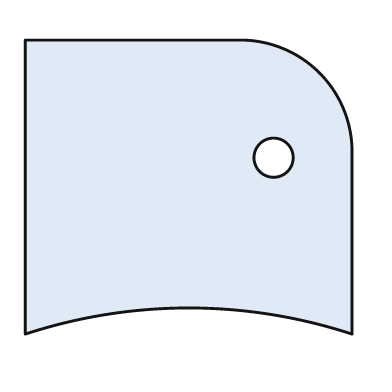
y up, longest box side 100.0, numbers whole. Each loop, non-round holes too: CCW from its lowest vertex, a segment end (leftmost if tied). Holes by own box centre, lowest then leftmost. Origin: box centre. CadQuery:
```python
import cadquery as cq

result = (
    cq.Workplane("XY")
    .moveTo(-50.0, -45.0)
    .threePointArc((0.0, -37.0), (50.0, -45.0))
    .lineTo(50.0, 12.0)
    .threePointArc((40.0, 35.0), (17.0, 45.0))
    .lineTo(-50.0, 45.0)
    .close()
    .moveTo(26.0, 9.0)
    .circle(6.0)
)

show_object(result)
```